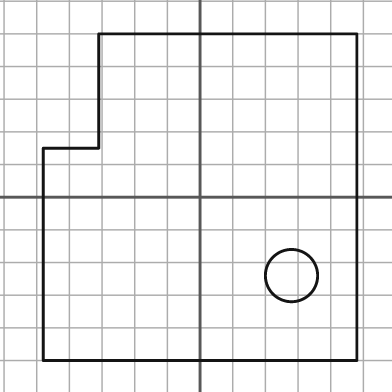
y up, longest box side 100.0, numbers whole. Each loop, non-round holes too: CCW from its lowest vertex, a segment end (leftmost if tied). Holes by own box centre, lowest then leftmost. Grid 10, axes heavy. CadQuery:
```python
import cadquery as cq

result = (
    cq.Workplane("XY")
    .moveTo(-48.0, -50.0)
    .lineTo(48.0, -50.0)
    .lineTo(48.0, 50.0)
    .lineTo(-31.0, 50.0)
    .lineTo(-31.0, 15.0)
    .lineTo(-48.0, 15.0)
    .close()
    .moveTo(28.0, -24.0)
    .circle(8.0)
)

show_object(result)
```